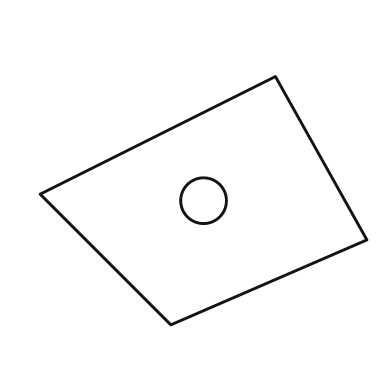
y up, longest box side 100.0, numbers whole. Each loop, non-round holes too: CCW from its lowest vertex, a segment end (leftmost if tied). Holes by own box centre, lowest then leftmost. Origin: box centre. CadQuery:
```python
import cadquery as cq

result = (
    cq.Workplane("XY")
    .moveTo(-10.0, -38.0)
    .lineTo(50.0, -12.0)
    .lineTo(22.0, 38.0)
    .lineTo(-50.0, 2.0)
    .close()
    .moveTo(0.0, 0.0)
    .circle(7.0)
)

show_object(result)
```